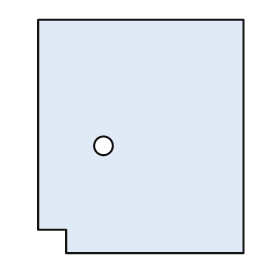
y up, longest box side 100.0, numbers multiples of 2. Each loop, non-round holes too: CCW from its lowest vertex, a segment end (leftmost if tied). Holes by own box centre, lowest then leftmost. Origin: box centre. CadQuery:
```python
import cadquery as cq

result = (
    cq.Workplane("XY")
    .moveTo(-32.0, -50.0)
    .lineTo(44.0, -50.0)
    .lineTo(44.0, 50.0)
    .lineTo(-44.0, 50.0)
    .lineTo(-44.0, -40.0)
    .lineTo(-32.0, -40.0)
    .close()
    .moveTo(-16.0, -4.0)
    .circle(4.0)
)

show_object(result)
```